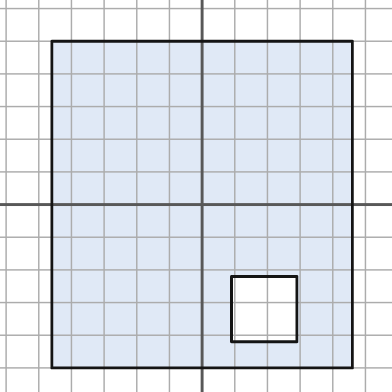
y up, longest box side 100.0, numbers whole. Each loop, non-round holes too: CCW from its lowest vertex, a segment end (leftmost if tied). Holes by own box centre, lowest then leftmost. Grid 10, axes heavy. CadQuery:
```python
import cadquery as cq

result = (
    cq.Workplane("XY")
    .moveTo(-46.0, -50.0)
    .lineTo(46.0, -50.0)
    .lineTo(46.0, 50.0)
    .lineTo(-46.0, 50.0)
    .close()
    .moveTo(9.0, -42.0)
    .lineTo(29.0, -42.0)
    .lineTo(29.0, -22.0)
    .lineTo(9.0, -22.0)
    .close()
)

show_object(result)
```